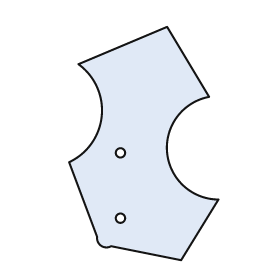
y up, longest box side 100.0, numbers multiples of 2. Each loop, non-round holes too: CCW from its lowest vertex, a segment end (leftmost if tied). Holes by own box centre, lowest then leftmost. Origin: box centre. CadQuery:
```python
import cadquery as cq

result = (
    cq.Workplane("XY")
    .moveTo(16.0, -50.0)
    .lineTo(32.0, -24.0)
    .threePointArc((10.0, -4.0), (28.0, 20.0))
    .lineTo(10.0, 50.0)
    .lineTo(-28.0, 34.0)
    .threePointArc((-18.0, 12.0), (-32.0, -8.0))
    .lineTo(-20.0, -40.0)
    .threePointArc((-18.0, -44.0), (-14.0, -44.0))
    .close()
    .moveTo(-10.0, -32.0)
    .circle(2.0)
    .moveTo(-10.0, -4.0)
    .circle(2.0)
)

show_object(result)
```